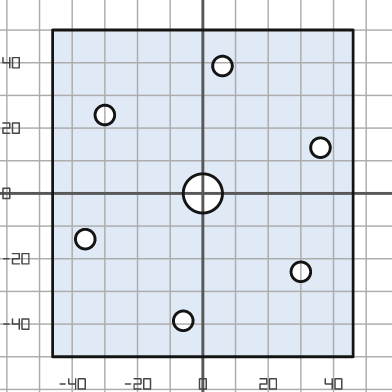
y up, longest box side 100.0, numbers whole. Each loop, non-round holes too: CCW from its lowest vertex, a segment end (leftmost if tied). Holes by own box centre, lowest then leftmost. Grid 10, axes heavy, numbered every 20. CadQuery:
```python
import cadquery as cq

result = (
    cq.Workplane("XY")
    .moveTo(-46.0, -50.0)
    .lineTo(46.0, -50.0)
    .lineTo(46.0, 50.0)
    .lineTo(-46.0, 50.0)
    .close()
    .moveTo(-6.0, -39.0)
    .circle(3.0)
    .moveTo(30.0, -24.0)
    .circle(3.0)
    .moveTo(-36.0, -14.0)
    .circle(3.0)
    .moveTo(0.0, 0.0)
    .circle(6.0)
    .moveTo(36.0, 14.0)
    .circle(3.0)
    .moveTo(-30.0, 24.0)
    .circle(3.0)
    .moveTo(6.0, 39.0)
    .circle(3.0)
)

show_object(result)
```